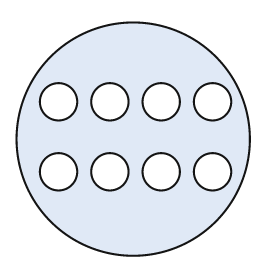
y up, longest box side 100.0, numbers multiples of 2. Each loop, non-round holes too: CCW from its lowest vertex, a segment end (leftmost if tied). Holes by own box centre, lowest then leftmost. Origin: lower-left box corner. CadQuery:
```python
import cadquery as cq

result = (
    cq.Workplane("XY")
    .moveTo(50.0, 50.0)
    .circle(50.0)
    .moveTo(18.0, 36.0)
    .circle(8.0)
    .moveTo(40.0, 36.0)
    .circle(8.0)
    .moveTo(62.0, 36.0)
    .circle(8.0)
    .moveTo(84.0, 36.0)
    .circle(8.0)
    .moveTo(18.0, 66.0)
    .circle(8.0)
    .moveTo(40.0, 66.0)
    .circle(8.0)
    .moveTo(62.0, 66.0)
    .circle(8.0)
    .moveTo(84.0, 66.0)
    .circle(8.0)
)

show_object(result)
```